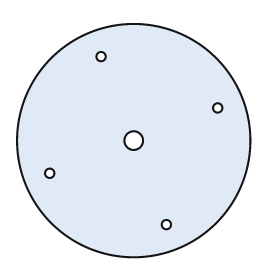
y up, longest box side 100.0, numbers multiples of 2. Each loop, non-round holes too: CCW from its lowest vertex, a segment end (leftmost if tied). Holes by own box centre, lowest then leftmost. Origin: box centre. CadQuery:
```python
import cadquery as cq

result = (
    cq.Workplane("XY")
    .moveTo(0.0, 0.0)
    .circle(50.0)
    .moveTo(14.0, -36.0)
    .circle(2.0)
    .moveTo(-36.0, -14.0)
    .circle(2.0)
    .moveTo(0.0, 0.0)
    .circle(4.0)
    .moveTo(36.0, 14.0)
    .circle(2.0)
    .moveTo(-14.0, 36.0)
    .circle(2.0)
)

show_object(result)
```